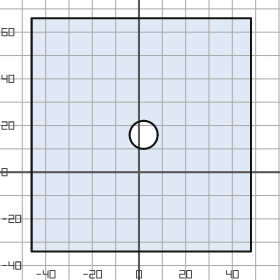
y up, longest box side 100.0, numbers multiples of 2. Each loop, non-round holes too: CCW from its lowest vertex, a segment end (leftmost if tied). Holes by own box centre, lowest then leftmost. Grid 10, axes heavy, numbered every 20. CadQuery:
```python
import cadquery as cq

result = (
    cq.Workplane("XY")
    .moveTo(-46.0, -34.0)
    .lineTo(48.0, -34.0)
    .lineTo(48.0, 66.0)
    .lineTo(-46.0, 66.0)
    .close()
    .moveTo(2.0, 16.0)
    .circle(6.0)
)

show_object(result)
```